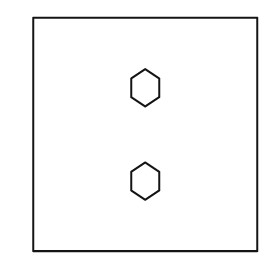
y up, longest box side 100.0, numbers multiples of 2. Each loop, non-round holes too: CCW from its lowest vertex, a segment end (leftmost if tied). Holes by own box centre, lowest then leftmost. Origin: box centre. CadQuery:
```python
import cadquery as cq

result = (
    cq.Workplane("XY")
    .moveTo(-48.0, -50.0)
    .lineTo(48.0, -50.0)
    .lineTo(48.0, 50.0)
    .lineTo(-48.0, 50.0)
    .close()
    .moveTo(0.0, -28.0)
    .lineTo(6.0, -24.0)
    .lineTo(6.0, -16.0)
    .lineTo(0.0, -12.0)
    .lineTo(-6.0, -16.0)
    .lineTo(-6.0, -24.0)
    .close()
    .moveTo(0.0, 12.0)
    .lineTo(6.0, 16.0)
    .lineTo(6.0, 24.0)
    .lineTo(0.0, 28.0)
    .lineTo(-6.0, 24.0)
    .lineTo(-6.0, 16.0)
    .close()
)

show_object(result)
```